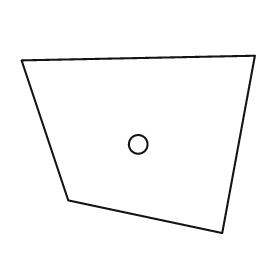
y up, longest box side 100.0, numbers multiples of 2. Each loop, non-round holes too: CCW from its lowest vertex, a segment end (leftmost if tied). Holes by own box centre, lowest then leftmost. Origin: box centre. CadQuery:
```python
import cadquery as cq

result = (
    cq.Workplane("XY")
    .moveTo(36.0, -38.0)
    .lineTo(50.0, 38.0)
    .lineTo(-50.0, 36.0)
    .lineTo(-30.0, -24.0)
    .close()
    .moveTo(0.0, 0.0)
    .circle(4.0)
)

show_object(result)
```